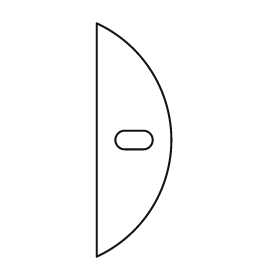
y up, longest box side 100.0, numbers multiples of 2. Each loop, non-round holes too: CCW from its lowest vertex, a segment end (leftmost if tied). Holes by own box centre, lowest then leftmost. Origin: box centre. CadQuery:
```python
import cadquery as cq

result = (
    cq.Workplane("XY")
    .moveTo(-16.0, -50.0)
    .threePointArc((16.0, 0.0), (-16.0, 50.0))
    .close()
    .moveTo(-4.0, -4.0)
    .lineTo(4.0, -4.0)
    .threePointArc((8.0, 0.0), (4.0, 4.0))
    .lineTo(-4.0, 4.0)
    .threePointArc((-8.0, 0.0), (-4.0, -4.0))
    .close()
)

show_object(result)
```